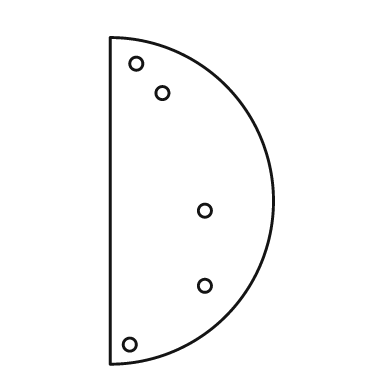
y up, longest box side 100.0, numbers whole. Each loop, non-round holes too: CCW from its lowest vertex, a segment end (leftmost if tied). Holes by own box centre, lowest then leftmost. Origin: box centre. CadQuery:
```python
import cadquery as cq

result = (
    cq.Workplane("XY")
    .moveTo(-25.0, -50.0)
    .threePointArc((25.0, 0.0), (-25.0, 50.0))
    .close()
    .moveTo(-19.0, -44.0)
    .circle(2.0)
    .moveTo(4.0, -26.0)
    .circle(2.0)
    .moveTo(4.0, -3.0)
    .circle(2.0)
    .moveTo(-9.0, 33.0)
    .circle(2.0)
    .moveTo(-17.0, 42.0)
    .circle(2.0)
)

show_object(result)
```